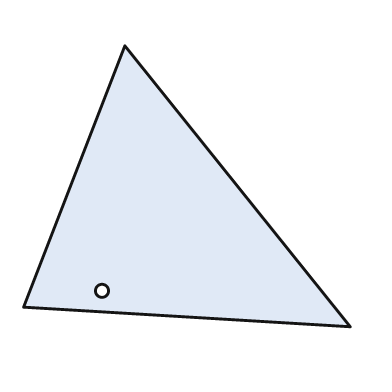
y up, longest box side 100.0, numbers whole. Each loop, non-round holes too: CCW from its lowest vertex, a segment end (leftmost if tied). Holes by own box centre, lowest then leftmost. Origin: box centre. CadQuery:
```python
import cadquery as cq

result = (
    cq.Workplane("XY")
    .moveTo(50.0, -43.0)
    .lineTo(-19.0, 43.0)
    .lineTo(-50.0, -37.0)
    .close()
    .moveTo(-26.0, -32.0)
    .circle(2.0)
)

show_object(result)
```